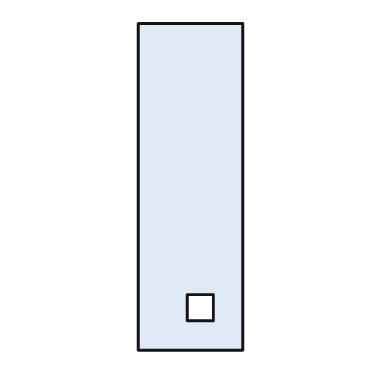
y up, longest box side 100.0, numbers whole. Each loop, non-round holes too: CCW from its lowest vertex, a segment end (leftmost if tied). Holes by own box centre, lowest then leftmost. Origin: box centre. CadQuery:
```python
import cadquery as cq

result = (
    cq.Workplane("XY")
    .moveTo(-16.0, -50.0)
    .lineTo(16.0, -50.0)
    .lineTo(16.0, 50.0)
    .lineTo(-16.0, 50.0)
    .close()
    .moveTo(-1.0, -41.0)
    .lineTo(7.0, -41.0)
    .lineTo(7.0, -33.0)
    .lineTo(-1.0, -33.0)
    .close()
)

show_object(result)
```